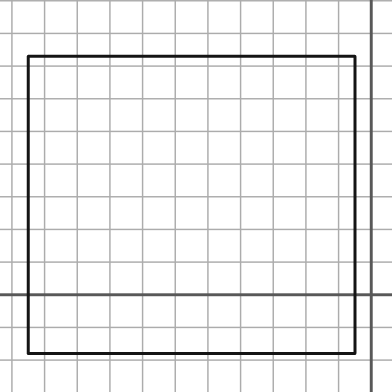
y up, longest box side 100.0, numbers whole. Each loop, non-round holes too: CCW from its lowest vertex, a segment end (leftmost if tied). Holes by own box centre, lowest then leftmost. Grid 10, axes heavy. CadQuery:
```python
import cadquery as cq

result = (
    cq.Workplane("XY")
    .moveTo(-105.0, -18.0)
    .lineTo(-5.0, -18.0)
    .lineTo(-5.0, 73.0)
    .lineTo(-105.0, 73.0)
    .close()
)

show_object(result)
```